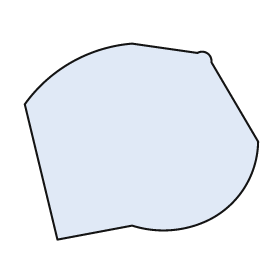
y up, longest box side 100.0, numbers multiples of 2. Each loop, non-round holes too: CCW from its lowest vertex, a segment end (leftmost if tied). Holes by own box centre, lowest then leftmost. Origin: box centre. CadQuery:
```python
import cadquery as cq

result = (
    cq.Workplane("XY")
    .moveTo(-36.0, -42.0)
    .lineTo(-4.0, -36.0)
    .threePointArc((12.0, -38.0), (28.0, -34.0))
    .threePointArc((44.0, -20.0), (50.0, 0.0))
    .lineTo(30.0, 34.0)
    .threePointArc((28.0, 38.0), (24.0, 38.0))
    .lineTo(-4.0, 42.0)
    .threePointArc((-30.0, 34.0), (-50.0, 16.0))
    .close()
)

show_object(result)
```